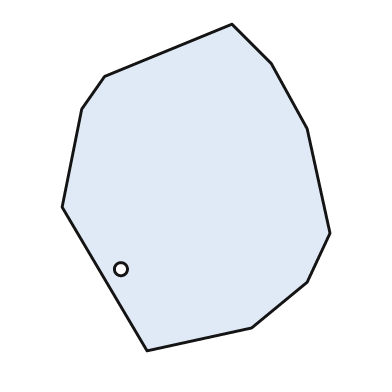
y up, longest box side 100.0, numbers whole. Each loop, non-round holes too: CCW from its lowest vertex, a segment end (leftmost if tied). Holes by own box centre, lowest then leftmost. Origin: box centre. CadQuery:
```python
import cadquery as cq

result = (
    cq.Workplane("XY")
    .moveTo(-15.0, -50.0)
    .lineTo(17.0, -43.0)
    .lineTo(34.0, -29.0)
    .lineTo(41.0, -14.0)
    .lineTo(34.0, 18.0)
    .lineTo(23.0, 38.0)
    .lineTo(11.0, 50.0)
    .lineTo(-28.0, 34.0)
    .lineTo(-35.0, 24.0)
    .lineTo(-41.0, -6.0)
    .close()
    .moveTo(-23.0, -25.0)
    .circle(2.0)
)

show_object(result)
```